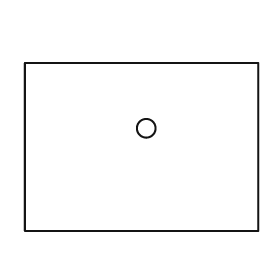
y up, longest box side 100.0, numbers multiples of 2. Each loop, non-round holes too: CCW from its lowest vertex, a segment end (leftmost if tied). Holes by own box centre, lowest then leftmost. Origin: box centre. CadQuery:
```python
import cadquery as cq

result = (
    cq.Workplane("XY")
    .moveTo(-50.0, -36.0)
    .lineTo(50.0, -36.0)
    .lineTo(50.0, 36.0)
    .lineTo(-50.0, 36.0)
    .close()
    .moveTo(2.0, 8.0)
    .circle(4.0)
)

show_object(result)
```